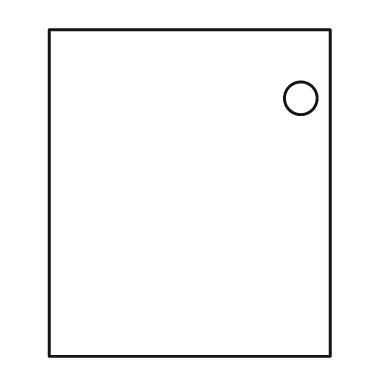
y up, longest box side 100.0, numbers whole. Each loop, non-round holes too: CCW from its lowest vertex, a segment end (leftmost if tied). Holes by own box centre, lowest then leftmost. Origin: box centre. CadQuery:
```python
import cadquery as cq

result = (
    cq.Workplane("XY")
    .moveTo(-43.0, -50.0)
    .lineTo(43.0, -50.0)
    .lineTo(43.0, 50.0)
    .lineTo(-43.0, 50.0)
    .close()
    .moveTo(34.0, 29.0)
    .circle(5.0)
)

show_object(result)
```